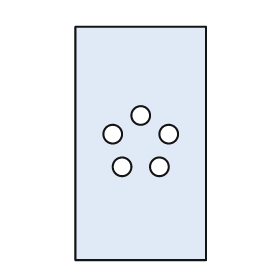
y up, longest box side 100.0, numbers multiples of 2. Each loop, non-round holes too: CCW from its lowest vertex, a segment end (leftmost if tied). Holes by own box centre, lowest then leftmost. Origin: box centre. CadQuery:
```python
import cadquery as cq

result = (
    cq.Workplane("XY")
    .moveTo(-28.0, -50.0)
    .lineTo(28.0, -50.0)
    .lineTo(28.0, 50.0)
    .lineTo(-28.0, 50.0)
    .close()
    .moveTo(-8.0, -10.0)
    .circle(4.0)
    .moveTo(8.0, -10.0)
    .circle(4.0)
    .moveTo(-12.0, 4.0)
    .circle(4.0)
    .moveTo(12.0, 4.0)
    .circle(4.0)
    .moveTo(0.0, 12.0)
    .circle(4.0)
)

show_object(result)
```